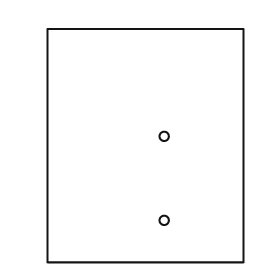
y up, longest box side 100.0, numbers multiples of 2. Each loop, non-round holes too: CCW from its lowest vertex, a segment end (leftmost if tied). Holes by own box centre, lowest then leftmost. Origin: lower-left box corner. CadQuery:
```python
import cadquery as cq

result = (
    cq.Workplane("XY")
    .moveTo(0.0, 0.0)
    .lineTo(84.0, 0.0)
    .lineTo(84.0, 100.0)
    .lineTo(0.0, 100.0)
    .close()
    .moveTo(50.0, 18.0)
    .circle(2.0)
    .moveTo(50.0, 54.0)
    .circle(2.0)
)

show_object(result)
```